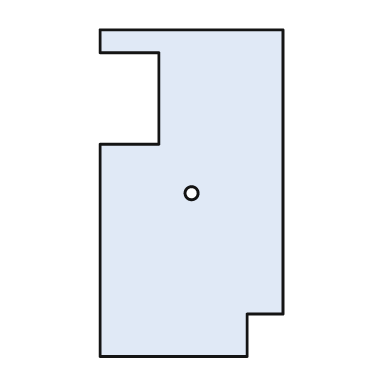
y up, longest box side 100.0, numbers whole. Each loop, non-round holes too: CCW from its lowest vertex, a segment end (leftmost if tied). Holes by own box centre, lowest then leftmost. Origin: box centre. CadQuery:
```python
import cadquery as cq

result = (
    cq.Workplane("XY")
    .moveTo(-28.0, -50.0)
    .lineTo(17.0, -50.0)
    .lineTo(17.0, -37.0)
    .lineTo(28.0, -37.0)
    .lineTo(28.0, 50.0)
    .lineTo(-28.0, 50.0)
    .lineTo(-28.0, 43.0)
    .lineTo(-10.0, 43.0)
    .lineTo(-10.0, 15.0)
    .lineTo(-28.0, 15.0)
    .close()
    .moveTo(0.0, 0.0)
    .circle(2.0)
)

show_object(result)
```